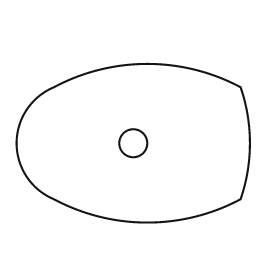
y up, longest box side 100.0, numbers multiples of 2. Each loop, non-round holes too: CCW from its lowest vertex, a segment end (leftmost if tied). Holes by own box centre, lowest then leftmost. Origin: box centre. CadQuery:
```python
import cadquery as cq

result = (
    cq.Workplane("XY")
    .moveTo(-34.0, -24.0)
    .threePointArc((6.0, -34.0), (46.0, -24.0))
    .threePointArc((50.0, 0.0), (46.0, 24.0))
    .threePointArc((6.0, 34.0), (-34.0, 24.0))
    .threePointArc((-50.0, 0.0), (-34.0, -24.0))
    .close()
    .moveTo(0.0, 0.0)
    .circle(6.0)
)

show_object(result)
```